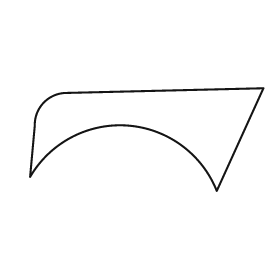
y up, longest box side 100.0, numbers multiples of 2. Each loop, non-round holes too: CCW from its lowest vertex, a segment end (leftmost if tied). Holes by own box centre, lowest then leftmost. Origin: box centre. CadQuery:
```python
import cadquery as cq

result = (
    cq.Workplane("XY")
    .moveTo(30.0, -22.0)
    .lineTo(50.0, 22.0)
    .lineTo(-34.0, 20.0)
    .threePointArc((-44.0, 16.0), (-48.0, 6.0))
    .lineTo(-50.0, -16.0)
    .threePointArc((-8.0, 6.0), (30.0, -22.0))
    .close()
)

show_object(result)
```